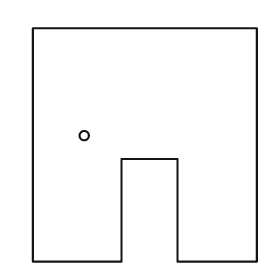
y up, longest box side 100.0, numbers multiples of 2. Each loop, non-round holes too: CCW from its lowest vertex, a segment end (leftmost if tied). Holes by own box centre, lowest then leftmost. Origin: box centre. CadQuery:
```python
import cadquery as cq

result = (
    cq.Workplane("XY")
    .moveTo(-48.0, -50.0)
    .lineTo(-10.0, -50.0)
    .lineTo(-10.0, -6.0)
    .lineTo(14.0, -6.0)
    .lineTo(14.0, -50.0)
    .lineTo(48.0, -50.0)
    .lineTo(48.0, 50.0)
    .lineTo(-48.0, 50.0)
    .close()
    .moveTo(-26.0, 4.0)
    .circle(2.0)
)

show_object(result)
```